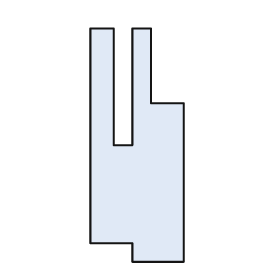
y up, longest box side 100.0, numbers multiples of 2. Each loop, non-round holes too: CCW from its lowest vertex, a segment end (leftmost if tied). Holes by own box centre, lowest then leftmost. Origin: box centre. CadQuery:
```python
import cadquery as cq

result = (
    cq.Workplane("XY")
    .moveTo(-2.0, -50.0)
    .lineTo(20.0, -50.0)
    .lineTo(20.0, 18.0)
    .lineTo(6.0, 18.0)
    .lineTo(6.0, 50.0)
    .lineTo(-2.0, 50.0)
    .lineTo(-2.0, 0.0)
    .lineTo(-10.0, 0.0)
    .lineTo(-10.0, 50.0)
    .lineTo(-20.0, 50.0)
    .lineTo(-20.0, -42.0)
    .lineTo(-2.0, -42.0)
    .close()
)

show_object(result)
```